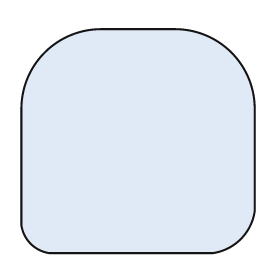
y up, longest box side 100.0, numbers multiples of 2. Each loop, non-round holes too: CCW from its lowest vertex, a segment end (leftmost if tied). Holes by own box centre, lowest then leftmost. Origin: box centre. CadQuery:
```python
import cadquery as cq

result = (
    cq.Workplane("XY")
    .moveTo(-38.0, -48.0)
    .lineTo(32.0, -48.0)
    .threePointArc((44.0, -42.0), (50.0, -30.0))
    .lineTo(50.0, 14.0)
    .threePointArc((40.0, 38.0), (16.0, 48.0))
    .lineTo(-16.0, 48.0)
    .threePointArc((-40.0, 38.0), (-50.0, 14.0))
    .lineTo(-50.0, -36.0)
    .threePointArc((-46.0, -44.0), (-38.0, -48.0))
    .close()
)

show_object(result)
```